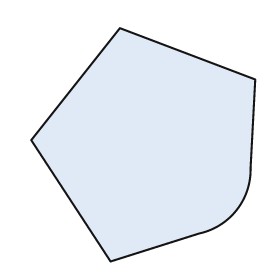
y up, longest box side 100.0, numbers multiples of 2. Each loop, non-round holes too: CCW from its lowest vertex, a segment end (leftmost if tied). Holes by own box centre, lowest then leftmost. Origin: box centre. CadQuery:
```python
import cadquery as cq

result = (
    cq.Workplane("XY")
    .moveTo(-14.0, -50.0)
    .lineTo(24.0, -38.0)
    .threePointArc((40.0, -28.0), (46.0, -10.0))
    .lineTo(48.0, 28.0)
    .lineTo(-10.0, 50.0)
    .lineTo(-48.0, 2.0)
    .close()
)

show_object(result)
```